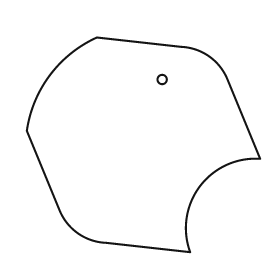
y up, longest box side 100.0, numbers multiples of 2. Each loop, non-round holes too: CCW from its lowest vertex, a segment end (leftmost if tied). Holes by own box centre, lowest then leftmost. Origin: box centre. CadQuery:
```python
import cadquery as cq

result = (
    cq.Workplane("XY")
    .moveTo(20.0, -46.0)
    .threePointArc((24.0, -18.0), (50.0, -6.0))
    .lineTo(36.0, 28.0)
    .threePointArc((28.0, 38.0), (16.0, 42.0))
    .lineTo(-20.0, 46.0)
    .threePointArc((-40.0, 30.0), (-50.0, 6.0))
    .lineTo(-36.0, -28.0)
    .threePointArc((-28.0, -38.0), (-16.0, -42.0))
    .close()
    .moveTo(8.0, 28.0)
    .circle(2.0)
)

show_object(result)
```